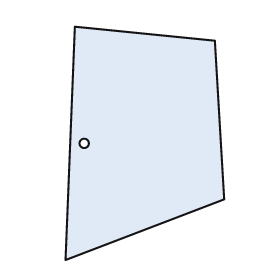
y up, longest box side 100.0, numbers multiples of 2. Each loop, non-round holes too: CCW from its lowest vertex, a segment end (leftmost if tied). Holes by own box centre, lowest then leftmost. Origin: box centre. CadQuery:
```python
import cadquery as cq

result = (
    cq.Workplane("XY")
    .moveTo(-34.0, -50.0)
    .lineTo(34.0, -24.0)
    .lineTo(30.0, 44.0)
    .lineTo(-30.0, 50.0)
    .close()
    .moveTo(-26.0, 0.0)
    .circle(2.0)
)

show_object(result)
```